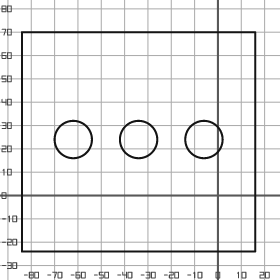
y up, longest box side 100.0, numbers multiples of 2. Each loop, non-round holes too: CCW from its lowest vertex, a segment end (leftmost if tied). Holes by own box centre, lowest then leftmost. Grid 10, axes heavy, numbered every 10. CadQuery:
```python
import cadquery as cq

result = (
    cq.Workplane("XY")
    .moveTo(-84.0, -24.0)
    .lineTo(16.0, -24.0)
    .lineTo(16.0, 70.0)
    .lineTo(-84.0, 70.0)
    .close()
    .moveTo(-62.0, 24.0)
    .circle(8.0)
    .moveTo(-34.0, 24.0)
    .circle(8.0)
    .moveTo(-6.0, 24.0)
    .circle(8.0)
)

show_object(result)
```